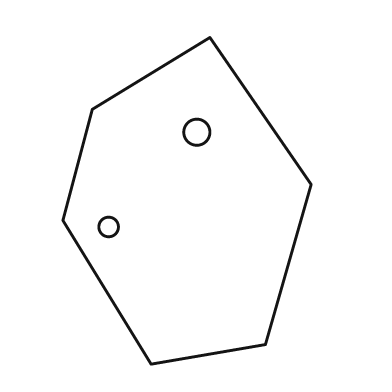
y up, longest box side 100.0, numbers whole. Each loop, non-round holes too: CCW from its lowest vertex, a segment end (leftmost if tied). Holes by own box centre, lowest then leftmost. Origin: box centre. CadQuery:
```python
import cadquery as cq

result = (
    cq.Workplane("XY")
    .moveTo(-11.0, -50.0)
    .lineTo(24.0, -44.0)
    .lineTo(38.0, 5.0)
    .lineTo(7.0, 50.0)
    .lineTo(-29.0, 28.0)
    .lineTo(-38.0, -6.0)
    .close()
    .moveTo(-24.0, -8.0)
    .circle(3.0)
    .moveTo(3.0, 21.0)
    .circle(4.0)
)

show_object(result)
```